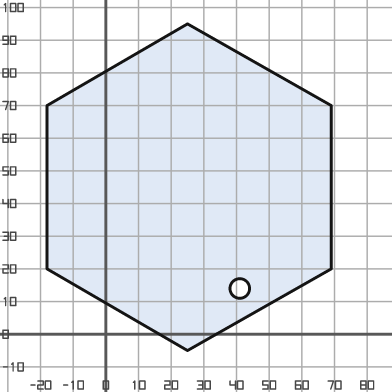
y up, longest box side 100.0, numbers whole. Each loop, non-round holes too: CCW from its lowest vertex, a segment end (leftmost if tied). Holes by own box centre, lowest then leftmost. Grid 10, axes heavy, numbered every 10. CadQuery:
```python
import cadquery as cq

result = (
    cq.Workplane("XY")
    .moveTo(25.0, -5.0)
    .lineTo(69.0, 20.0)
    .lineTo(69.0, 70.0)
    .lineTo(25.0, 95.0)
    .lineTo(-18.0, 70.0)
    .lineTo(-18.0, 20.0)
    .close()
    .moveTo(41.0, 14.0)
    .circle(3.0)
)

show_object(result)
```